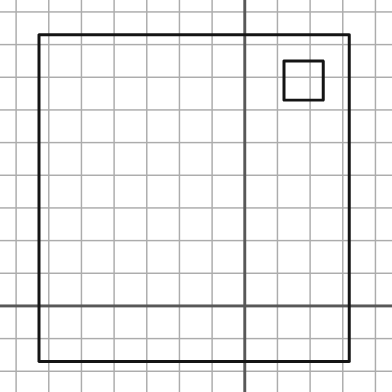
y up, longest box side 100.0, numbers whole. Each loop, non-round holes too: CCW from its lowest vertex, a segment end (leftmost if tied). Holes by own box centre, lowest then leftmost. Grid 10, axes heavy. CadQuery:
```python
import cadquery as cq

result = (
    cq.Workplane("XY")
    .moveTo(-63.0, -17.0)
    .lineTo(32.0, -17.0)
    .lineTo(32.0, 83.0)
    .lineTo(-63.0, 83.0)
    .close()
    .moveTo(12.0, 63.0)
    .lineTo(24.0, 63.0)
    .lineTo(24.0, 75.0)
    .lineTo(12.0, 75.0)
    .close()
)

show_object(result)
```